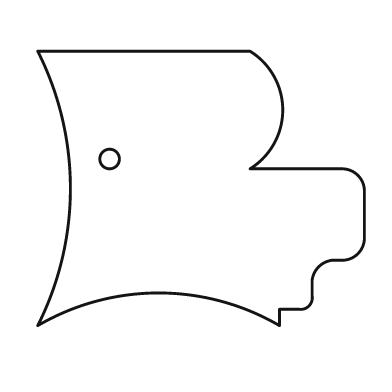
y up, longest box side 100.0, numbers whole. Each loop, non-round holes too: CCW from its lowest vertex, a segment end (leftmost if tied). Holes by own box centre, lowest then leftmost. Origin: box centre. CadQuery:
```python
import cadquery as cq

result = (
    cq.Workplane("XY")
    .moveTo(-50.0, -42.0)
    .threePointArc((-13.0, -32.0), (24.0, -42.0))
    .lineTo(24.0, -37.0)
    .lineTo(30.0, -37.0)
    .threePointArc((33.0, -36.0), (34.0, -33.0))
    .lineTo(34.0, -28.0)
    .threePointArc((36.0, -24.0), (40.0, -22.0))
    .lineTo(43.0, -22.0)
    .threePointArc((48.0, -20.0), (50.0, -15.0))
    .lineTo(50.0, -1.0)
    .threePointArc((48.0, 4.0), (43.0, 6.0))
    .lineTo(15.0, 6.0)
    .threePointArc((25.0, 24.0), (15.0, 42.0))
    .lineTo(-50.0, 42.0)
    .threePointArc((-40.0, 0.0), (-50.0, -42.0))
    .close()
    .moveTo(-28.0, 9.0)
    .circle(3.0)
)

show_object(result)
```